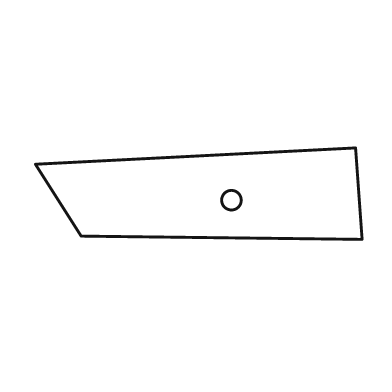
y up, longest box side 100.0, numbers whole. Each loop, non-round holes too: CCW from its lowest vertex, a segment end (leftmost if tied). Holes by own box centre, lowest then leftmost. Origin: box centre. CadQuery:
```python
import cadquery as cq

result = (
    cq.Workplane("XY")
    .moveTo(50.0, -14.0)
    .lineTo(48.0, 14.0)
    .lineTo(-50.0, 9.0)
    .lineTo(-36.0, -13.0)
    .close()
    .moveTo(10.0, -2.0)
    .circle(3.0)
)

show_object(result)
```